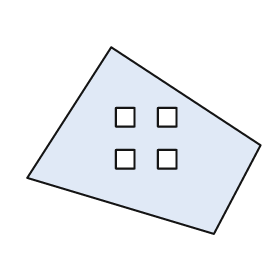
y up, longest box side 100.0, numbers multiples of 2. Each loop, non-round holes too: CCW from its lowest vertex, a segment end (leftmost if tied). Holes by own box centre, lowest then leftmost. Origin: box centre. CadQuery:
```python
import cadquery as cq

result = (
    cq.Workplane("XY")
    .moveTo(30.0, -40.0)
    .lineTo(50.0, -2.0)
    .lineTo(-14.0, 40.0)
    .lineTo(-50.0, -16.0)
    .close()
    .moveTo(-12.0, -12.0)
    .lineTo(-4.0, -12.0)
    .lineTo(-4.0, -4.0)
    .lineTo(-12.0, -4.0)
    .close()
    .moveTo(6.0, -12.0)
    .lineTo(14.0, -12.0)
    .lineTo(14.0, -4.0)
    .lineTo(6.0, -4.0)
    .close()
    .moveTo(-12.0, 6.0)
    .lineTo(-4.0, 6.0)
    .lineTo(-4.0, 14.0)
    .lineTo(-12.0, 14.0)
    .close()
    .moveTo(6.0, 6.0)
    .lineTo(14.0, 6.0)
    .lineTo(14.0, 14.0)
    .lineTo(6.0, 14.0)
    .close()
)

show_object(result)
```